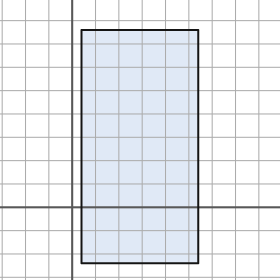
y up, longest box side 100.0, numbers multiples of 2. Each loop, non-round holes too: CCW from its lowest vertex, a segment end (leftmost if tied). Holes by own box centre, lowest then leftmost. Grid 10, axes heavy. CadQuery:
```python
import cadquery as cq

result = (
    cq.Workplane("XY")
    .moveTo(4.0, -24.0)
    .lineTo(54.0, -24.0)
    .lineTo(54.0, 76.0)
    .lineTo(4.0, 76.0)
    .close()
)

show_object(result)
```